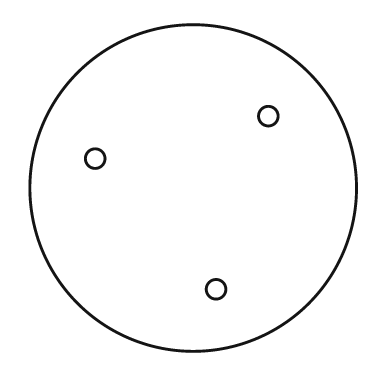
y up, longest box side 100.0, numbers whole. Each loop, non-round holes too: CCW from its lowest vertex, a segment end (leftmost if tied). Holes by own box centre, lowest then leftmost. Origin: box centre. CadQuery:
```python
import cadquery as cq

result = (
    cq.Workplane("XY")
    .moveTo(0.0, 0.0)
    .circle(50.0)
    .moveTo(7.0, -31.0)
    .circle(3.0)
    .moveTo(-30.0, 9.0)
    .circle(3.0)
    .moveTo(23.0, 22.0)
    .circle(3.0)
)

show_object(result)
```